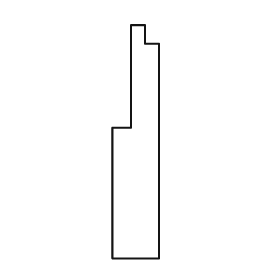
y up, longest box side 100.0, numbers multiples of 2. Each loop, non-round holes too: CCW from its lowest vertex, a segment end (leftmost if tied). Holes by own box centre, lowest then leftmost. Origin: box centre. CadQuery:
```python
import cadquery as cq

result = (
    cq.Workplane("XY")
    .moveTo(-10.0, -50.0)
    .lineTo(10.0, -50.0)
    .lineTo(10.0, 42.0)
    .lineTo(4.0, 42.0)
    .lineTo(4.0, 50.0)
    .lineTo(-2.0, 50.0)
    .lineTo(-2.0, 6.0)
    .lineTo(-10.0, 6.0)
    .close()
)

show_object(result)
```